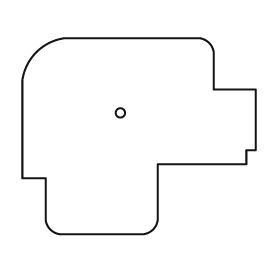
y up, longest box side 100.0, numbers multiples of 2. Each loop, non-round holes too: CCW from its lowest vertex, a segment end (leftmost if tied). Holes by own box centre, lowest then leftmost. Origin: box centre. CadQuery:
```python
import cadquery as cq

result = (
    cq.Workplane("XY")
    .moveTo(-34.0, -42.0)
    .lineTo(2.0, -42.0)
    .threePointArc((6.0, -40.0), (8.0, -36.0))
    .lineTo(8.0, -12.0)
    .lineTo(46.0, -12.0)
    .lineTo(46.0, -6.0)
    .lineTo(50.0, -6.0)
    .lineTo(50.0, 20.0)
    .lineTo(32.0, 20.0)
    .lineTo(32.0, 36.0)
    .threePointArc((30.0, 40.0), (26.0, 42.0))
    .lineTo(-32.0, 42.0)
    .threePointArc((-44.0, 36.0), (-50.0, 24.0))
    .lineTo(-50.0, -18.0)
    .lineTo(-40.0, -18.0)
    .lineTo(-40.0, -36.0)
    .threePointArc((-38.0, -40.0), (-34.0, -42.0))
    .close()
    .moveTo(-8.0, 10.0)
    .circle(2.0)
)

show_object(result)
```